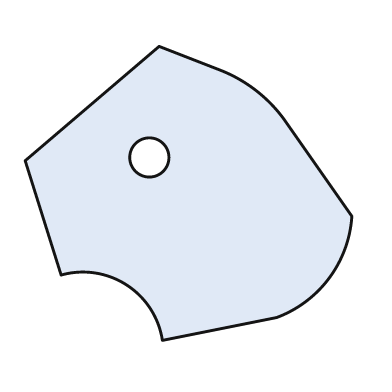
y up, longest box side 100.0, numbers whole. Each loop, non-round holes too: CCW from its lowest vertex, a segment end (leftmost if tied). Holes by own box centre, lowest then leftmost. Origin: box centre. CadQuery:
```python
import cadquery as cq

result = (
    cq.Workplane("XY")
    .moveTo(-8.0, -45.0)
    .lineTo(27.0, -38.0)
    .threePointArc((43.0, -26.0), (50.0, -7.0))
    .lineTo(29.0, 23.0)
    .threePointArc((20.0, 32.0), (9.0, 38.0))
    .lineTo(-9.0, 45.0)
    .lineTo(-50.0, 10.0)
    .lineTo(-39.0, -25.0)
    .threePointArc((-19.0, -28.0), (-8.0, -45.0))
    .close()
    .moveTo(-12.0, 11.0)
    .circle(6.0)
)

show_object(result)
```